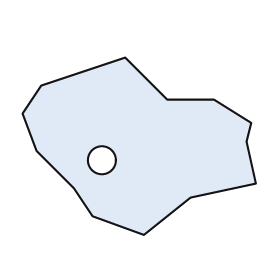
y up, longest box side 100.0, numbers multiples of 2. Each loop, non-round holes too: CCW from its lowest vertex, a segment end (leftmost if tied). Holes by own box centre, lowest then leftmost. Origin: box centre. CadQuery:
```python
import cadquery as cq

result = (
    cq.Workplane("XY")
    .moveTo(2.0, -38.0)
    .lineTo(22.0, -22.0)
    .lineTo(50.0, -16.0)
    .lineTo(46.0, 2.0)
    .lineTo(48.0, 10.0)
    .lineTo(32.0, 20.0)
    .lineTo(12.0, 20.0)
    .lineTo(-6.0, 38.0)
    .lineTo(-42.0, 26.0)
    .lineTo(-50.0, 14.0)
    .lineTo(-44.0, -2.0)
    .lineTo(-28.0, -18.0)
    .lineTo(-20.0, -30.0)
    .close()
    .moveTo(-16.0, -6.0)
    .circle(6.0)
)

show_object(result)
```